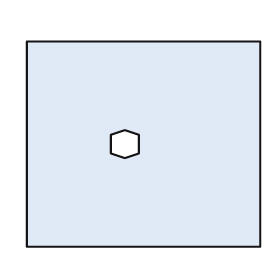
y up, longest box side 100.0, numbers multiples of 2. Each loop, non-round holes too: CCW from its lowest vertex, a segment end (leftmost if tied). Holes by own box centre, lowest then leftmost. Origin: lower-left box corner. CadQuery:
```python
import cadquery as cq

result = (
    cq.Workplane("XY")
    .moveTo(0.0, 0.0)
    .lineTo(100.0, 0.0)
    .lineTo(100.0, 88.0)
    .lineTo(0.0, 88.0)
    .close()
    .moveTo(42.0, 38.0)
    .lineTo(48.0, 40.0)
    .lineTo(48.0, 48.0)
    .lineTo(42.0, 50.0)
    .lineTo(36.0, 48.0)
    .lineTo(36.0, 40.0)
    .close()
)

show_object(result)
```